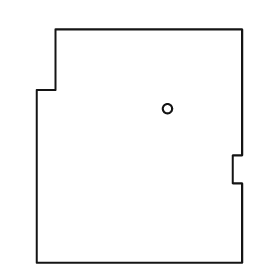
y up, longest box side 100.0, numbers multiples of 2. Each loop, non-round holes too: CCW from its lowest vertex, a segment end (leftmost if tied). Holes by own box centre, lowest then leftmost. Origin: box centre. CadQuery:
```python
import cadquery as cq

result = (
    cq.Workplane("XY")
    .moveTo(-44.0, -50.0)
    .lineTo(44.0, -50.0)
    .lineTo(44.0, -16.0)
    .lineTo(40.0, -16.0)
    .lineTo(40.0, -4.0)
    .lineTo(44.0, -4.0)
    .lineTo(44.0, 50.0)
    .lineTo(-36.0, 50.0)
    .lineTo(-36.0, 24.0)
    .lineTo(-44.0, 24.0)
    .close()
    .moveTo(12.0, 16.0)
    .circle(2.0)
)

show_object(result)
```